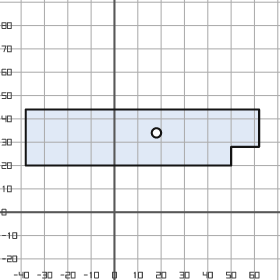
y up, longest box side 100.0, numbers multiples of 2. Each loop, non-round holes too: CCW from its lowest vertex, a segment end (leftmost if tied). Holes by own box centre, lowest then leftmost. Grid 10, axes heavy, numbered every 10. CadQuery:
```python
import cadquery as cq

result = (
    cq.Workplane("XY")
    .moveTo(-38.0, 20.0)
    .lineTo(50.0, 20.0)
    .lineTo(50.0, 28.0)
    .lineTo(62.0, 28.0)
    .lineTo(62.0, 44.0)
    .lineTo(-38.0, 44.0)
    .close()
    .moveTo(18.0, 34.0)
    .circle(2.0)
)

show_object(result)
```